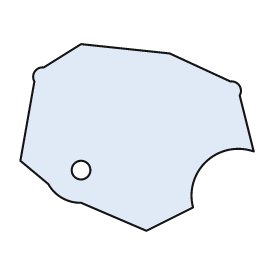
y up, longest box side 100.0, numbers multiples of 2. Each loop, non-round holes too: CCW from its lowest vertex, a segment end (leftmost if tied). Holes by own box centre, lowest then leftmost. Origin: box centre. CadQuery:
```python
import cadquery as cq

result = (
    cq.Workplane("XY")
    .moveTo(4.0, -40.0)
    .lineTo(24.0, -30.0)
    .threePointArc((30.0, -10.0), (50.0, -6.0))
    .lineTo(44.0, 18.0)
    .threePointArc((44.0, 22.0), (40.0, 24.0))
    .lineTo(14.0, 36.0)
    .lineTo(-24.0, 40.0)
    .lineTo(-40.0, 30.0)
    .threePointArc((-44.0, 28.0), (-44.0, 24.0))
    .lineTo(-50.0, -10.0)
    .lineTo(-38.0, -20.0)
    .threePointArc((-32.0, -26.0), (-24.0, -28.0))
    .close()
    .moveTo(-24.0, -14.0)
    .circle(4.0)
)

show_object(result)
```